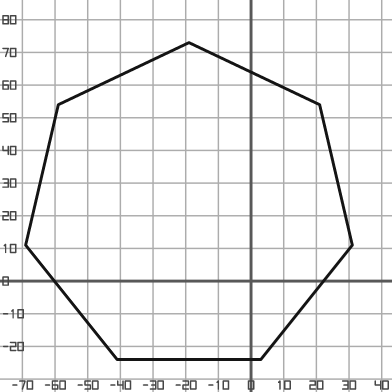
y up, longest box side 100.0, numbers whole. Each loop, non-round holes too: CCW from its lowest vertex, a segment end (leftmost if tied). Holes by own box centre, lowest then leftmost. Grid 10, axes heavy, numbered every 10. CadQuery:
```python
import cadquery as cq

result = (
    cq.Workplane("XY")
    .moveTo(-41.0, -24.0)
    .lineTo(3.0, -24.0)
    .lineTo(31.0, 11.0)
    .lineTo(21.0, 54.0)
    .lineTo(-19.0, 73.0)
    .lineTo(-59.0, 54.0)
    .lineTo(-69.0, 11.0)
    .close()
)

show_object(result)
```